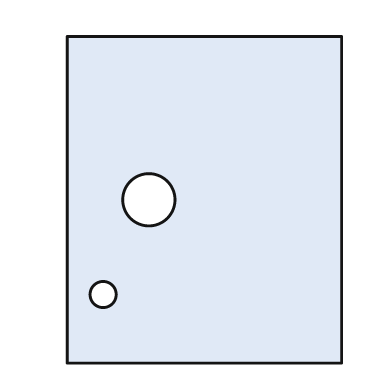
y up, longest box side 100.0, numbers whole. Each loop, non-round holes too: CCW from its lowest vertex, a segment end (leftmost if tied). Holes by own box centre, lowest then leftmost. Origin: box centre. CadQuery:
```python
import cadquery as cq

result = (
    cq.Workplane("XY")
    .moveTo(-42.0, -50.0)
    .lineTo(42.0, -50.0)
    .lineTo(42.0, 50.0)
    .lineTo(-42.0, 50.0)
    .close()
    .moveTo(-31.0, -29.0)
    .circle(4.0)
    .moveTo(-17.0, 0.0)
    .circle(8.0)
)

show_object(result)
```